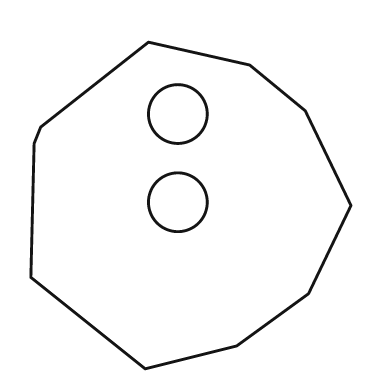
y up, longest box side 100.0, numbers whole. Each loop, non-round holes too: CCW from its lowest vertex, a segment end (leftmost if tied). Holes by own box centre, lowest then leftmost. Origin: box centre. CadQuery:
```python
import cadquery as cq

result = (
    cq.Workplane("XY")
    .moveTo(-14.0, -50.0)
    .lineTo(14.0, -43.0)
    .lineTo(36.0, -27.0)
    .lineTo(49.0, 0.0)
    .lineTo(35.0, 29.0)
    .lineTo(18.0, 43.0)
    .lineTo(-13.0, 50.0)
    .lineTo(-46.0, 24.0)
    .lineTo(-48.0, 19.0)
    .lineTo(-49.0, -22.0)
    .close()
    .moveTo(-4.0, 1.0)
    .circle(9.0)
    .moveTo(-4.0, 28.0)
    .circle(9.0)
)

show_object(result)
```